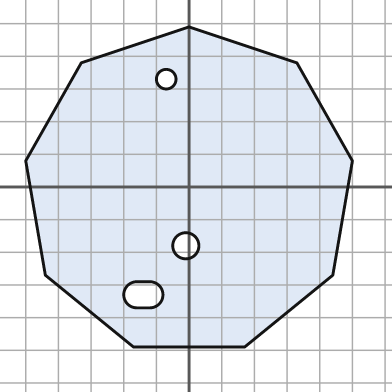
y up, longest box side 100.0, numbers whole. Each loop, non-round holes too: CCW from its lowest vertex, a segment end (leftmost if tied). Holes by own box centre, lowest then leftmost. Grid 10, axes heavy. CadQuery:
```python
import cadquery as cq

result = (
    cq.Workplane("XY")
    .moveTo(-17.0, -49.0)
    .lineTo(17.0, -49.0)
    .lineTo(44.0, -27.0)
    .lineTo(50.0, 8.0)
    .lineTo(33.0, 38.0)
    .lineTo(0.0, 49.0)
    .lineTo(-33.0, 38.0)
    .lineTo(-50.0, 8.0)
    .lineTo(-44.0, -27.0)
    .close()
    .moveTo(-16.0, -37.0)
    .lineTo(-12.0, -37.0)
    .threePointArc((-8.0, -33.0), (-12.0, -29.0))
    .lineTo(-16.0, -29.0)
    .threePointArc((-20.0, -33.0), (-16.0, -37.0))
    .close()
    .moveTo(-1.0, -18.0)
    .circle(4.0)
    .moveTo(-7.0, 33.0)
    .circle(3.0)
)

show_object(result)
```